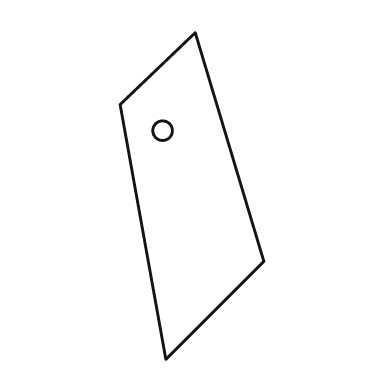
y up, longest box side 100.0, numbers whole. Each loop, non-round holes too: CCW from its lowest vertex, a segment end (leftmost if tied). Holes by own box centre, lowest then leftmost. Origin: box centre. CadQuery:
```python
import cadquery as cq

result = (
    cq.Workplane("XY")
    .moveTo(-8.0, -50.0)
    .lineTo(22.0, -20.0)
    .lineTo(1.0, 50.0)
    .lineTo(-22.0, 28.0)
    .close()
    .moveTo(-9.0, 20.0)
    .circle(3.0)
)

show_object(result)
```